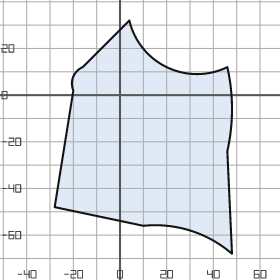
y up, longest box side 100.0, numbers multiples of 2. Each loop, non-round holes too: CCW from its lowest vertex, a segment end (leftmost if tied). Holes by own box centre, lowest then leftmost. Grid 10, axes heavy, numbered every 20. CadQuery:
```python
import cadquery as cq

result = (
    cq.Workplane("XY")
    .moveTo(48.0, -68.0)
    .lineTo(46.0, -24.0)
    .threePointArc((48.0, -6.0), (46.0, 12.0))
    .threePointArc((20.0, 12.0), (4.0, 32.0))
    .lineTo(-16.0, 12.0)
    .threePointArc((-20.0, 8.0), (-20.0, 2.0))
    .lineTo(-28.0, -48.0)
    .lineTo(10.0, -56.0)
    .threePointArc((30.0, -58.0), (48.0, -68.0))
    .close()
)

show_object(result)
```